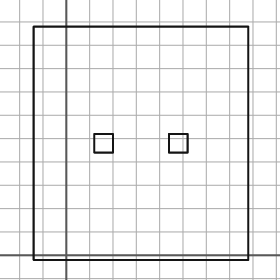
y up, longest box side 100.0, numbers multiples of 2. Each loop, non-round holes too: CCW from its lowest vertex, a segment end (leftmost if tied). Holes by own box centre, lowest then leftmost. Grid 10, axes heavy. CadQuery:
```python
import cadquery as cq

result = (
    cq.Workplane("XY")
    .moveTo(-14.0, -2.0)
    .lineTo(78.0, -2.0)
    .lineTo(78.0, 98.0)
    .lineTo(-14.0, 98.0)
    .close()
    .moveTo(12.0, 44.0)
    .lineTo(20.0, 44.0)
    .lineTo(20.0, 52.0)
    .lineTo(12.0, 52.0)
    .close()
    .moveTo(44.0, 44.0)
    .lineTo(52.0, 44.0)
    .lineTo(52.0, 52.0)
    .lineTo(44.0, 52.0)
    .close()
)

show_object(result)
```